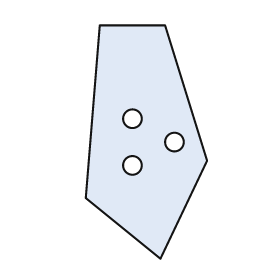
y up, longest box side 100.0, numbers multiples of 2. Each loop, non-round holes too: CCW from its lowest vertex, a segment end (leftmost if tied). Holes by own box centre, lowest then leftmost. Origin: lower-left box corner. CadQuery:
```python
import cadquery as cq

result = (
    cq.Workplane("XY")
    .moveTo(32.0, 0.0)
    .lineTo(52.0, 42.0)
    .lineTo(34.0, 100.0)
    .lineTo(6.0, 100.0)
    .lineTo(0.0, 26.0)
    .close()
    .moveTo(20.0, 40.0)
    .circle(4.0)
    .moveTo(38.0, 50.0)
    .circle(4.0)
    .moveTo(20.0, 60.0)
    .circle(4.0)
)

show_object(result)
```